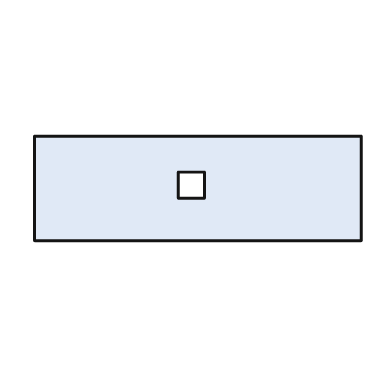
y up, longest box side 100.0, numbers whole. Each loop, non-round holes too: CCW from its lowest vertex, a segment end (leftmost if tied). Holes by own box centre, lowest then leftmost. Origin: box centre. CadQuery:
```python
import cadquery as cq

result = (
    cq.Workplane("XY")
    .moveTo(-50.0, -16.0)
    .lineTo(50.0, -16.0)
    .lineTo(50.0, 16.0)
    .lineTo(-50.0, 16.0)
    .close()
    .moveTo(-6.0, -3.0)
    .lineTo(2.0, -3.0)
    .lineTo(2.0, 5.0)
    .lineTo(-6.0, 5.0)
    .close()
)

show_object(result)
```